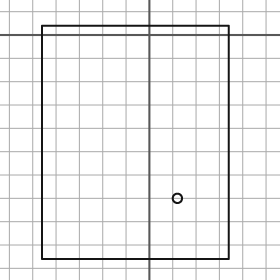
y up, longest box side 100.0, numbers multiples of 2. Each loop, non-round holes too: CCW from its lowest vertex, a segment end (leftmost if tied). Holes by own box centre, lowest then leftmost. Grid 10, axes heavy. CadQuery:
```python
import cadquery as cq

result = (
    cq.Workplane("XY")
    .moveTo(-46.0, -96.0)
    .lineTo(34.0, -96.0)
    .lineTo(34.0, 4.0)
    .lineTo(-46.0, 4.0)
    .close()
    .moveTo(12.0, -70.0)
    .circle(2.0)
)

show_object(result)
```